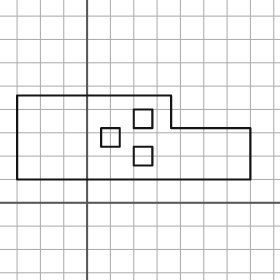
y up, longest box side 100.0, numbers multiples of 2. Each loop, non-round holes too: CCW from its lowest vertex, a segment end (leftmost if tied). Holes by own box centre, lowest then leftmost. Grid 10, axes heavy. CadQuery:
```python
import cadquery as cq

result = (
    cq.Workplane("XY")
    .moveTo(-30.0, 10.0)
    .lineTo(70.0, 10.0)
    .lineTo(70.0, 32.0)
    .lineTo(36.0, 32.0)
    .lineTo(36.0, 46.0)
    .lineTo(-30.0, 46.0)
    .close()
    .moveTo(20.0, 16.0)
    .lineTo(28.0, 16.0)
    .lineTo(28.0, 24.0)
    .lineTo(20.0, 24.0)
    .close()
    .moveTo(6.0, 24.0)
    .lineTo(14.0, 24.0)
    .lineTo(14.0, 32.0)
    .lineTo(6.0, 32.0)
    .close()
    .moveTo(20.0, 32.0)
    .lineTo(28.0, 32.0)
    .lineTo(28.0, 40.0)
    .lineTo(20.0, 40.0)
    .close()
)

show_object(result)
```